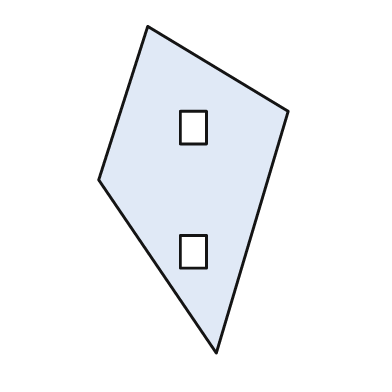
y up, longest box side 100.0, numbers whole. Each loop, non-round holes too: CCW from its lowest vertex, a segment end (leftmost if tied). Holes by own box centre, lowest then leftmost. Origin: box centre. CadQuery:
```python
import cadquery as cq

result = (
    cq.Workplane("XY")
    .moveTo(7.0, -50.0)
    .lineTo(29.0, 24.0)
    .lineTo(-14.0, 50.0)
    .lineTo(-29.0, 3.0)
    .close()
    .moveTo(-4.0, -24.0)
    .lineTo(4.0, -24.0)
    .lineTo(4.0, -14.0)
    .lineTo(-4.0, -14.0)
    .close()
    .moveTo(-4.0, 14.0)
    .lineTo(4.0, 14.0)
    .lineTo(4.0, 24.0)
    .lineTo(-4.0, 24.0)
    .close()
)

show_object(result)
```